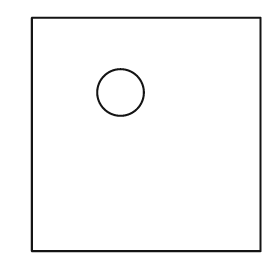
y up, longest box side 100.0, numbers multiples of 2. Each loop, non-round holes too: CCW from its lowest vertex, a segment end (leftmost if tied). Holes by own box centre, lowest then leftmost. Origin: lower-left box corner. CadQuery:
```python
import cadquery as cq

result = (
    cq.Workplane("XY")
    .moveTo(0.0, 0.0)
    .lineTo(98.0, 0.0)
    .lineTo(98.0, 100.0)
    .lineTo(0.0, 100.0)
    .close()
    .moveTo(38.0, 68.0)
    .circle(10.0)
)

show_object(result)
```